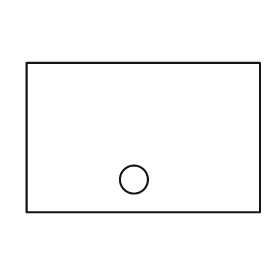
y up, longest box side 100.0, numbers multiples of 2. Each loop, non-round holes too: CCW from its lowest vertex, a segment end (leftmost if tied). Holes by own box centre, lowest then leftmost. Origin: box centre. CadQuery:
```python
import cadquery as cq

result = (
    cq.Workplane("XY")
    .moveTo(-50.0, -32.0)
    .lineTo(50.0, -32.0)
    .lineTo(50.0, 32.0)
    .lineTo(-50.0, 32.0)
    .close()
    .moveTo(-4.0, -18.0)
    .circle(6.0)
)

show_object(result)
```